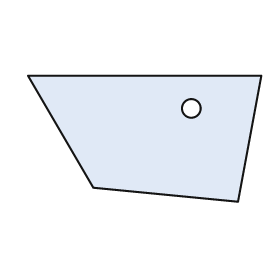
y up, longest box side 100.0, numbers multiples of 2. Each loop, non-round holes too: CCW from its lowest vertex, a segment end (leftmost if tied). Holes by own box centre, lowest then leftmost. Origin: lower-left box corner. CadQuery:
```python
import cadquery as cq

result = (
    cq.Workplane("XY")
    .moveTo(90.0, 0.0)
    .lineTo(100.0, 54.0)
    .lineTo(0.0, 54.0)
    .lineTo(28.0, 6.0)
    .close()
    .moveTo(70.0, 40.0)
    .circle(4.0)
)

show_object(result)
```